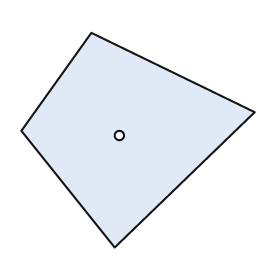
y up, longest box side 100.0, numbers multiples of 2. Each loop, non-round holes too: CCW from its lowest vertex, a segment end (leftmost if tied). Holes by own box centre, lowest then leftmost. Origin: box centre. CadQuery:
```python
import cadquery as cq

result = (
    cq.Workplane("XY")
    .moveTo(-10.0, -46.0)
    .lineTo(50.0, 12.0)
    .lineTo(-20.0, 46.0)
    .lineTo(-50.0, 4.0)
    .close()
    .moveTo(-8.0, 2.0)
    .circle(2.0)
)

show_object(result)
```